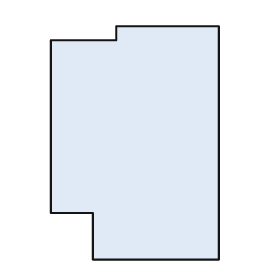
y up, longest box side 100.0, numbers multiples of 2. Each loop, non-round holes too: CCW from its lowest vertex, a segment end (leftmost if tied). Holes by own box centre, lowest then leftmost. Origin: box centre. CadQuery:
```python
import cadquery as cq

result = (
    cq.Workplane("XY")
    .moveTo(-18.0, -50.0)
    .lineTo(36.0, -50.0)
    .lineTo(36.0, 50.0)
    .lineTo(-8.0, 50.0)
    .lineTo(-8.0, 44.0)
    .lineTo(-36.0, 44.0)
    .lineTo(-36.0, -30.0)
    .lineTo(-18.0, -30.0)
    .close()
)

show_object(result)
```